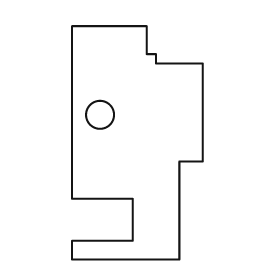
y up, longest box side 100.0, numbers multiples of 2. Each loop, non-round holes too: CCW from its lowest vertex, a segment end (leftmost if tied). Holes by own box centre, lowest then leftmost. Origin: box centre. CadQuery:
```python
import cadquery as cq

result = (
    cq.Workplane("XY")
    .moveTo(-28.0, -50.0)
    .lineTo(18.0, -50.0)
    .lineTo(18.0, -8.0)
    .lineTo(28.0, -8.0)
    .lineTo(28.0, 34.0)
    .lineTo(8.0, 34.0)
    .lineTo(8.0, 38.0)
    .lineTo(4.0, 38.0)
    .lineTo(4.0, 50.0)
    .lineTo(-28.0, 50.0)
    .lineTo(-28.0, -24.0)
    .lineTo(-2.0, -24.0)
    .lineTo(-2.0, -42.0)
    .lineTo(-28.0, -42.0)
    .close()
    .moveTo(-16.0, 12.0)
    .circle(6.0)
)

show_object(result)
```